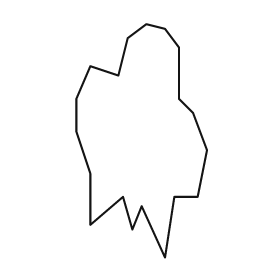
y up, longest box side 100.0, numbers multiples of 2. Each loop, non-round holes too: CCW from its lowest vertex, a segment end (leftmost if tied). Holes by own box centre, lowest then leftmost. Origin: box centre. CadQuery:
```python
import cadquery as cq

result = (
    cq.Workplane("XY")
    .moveTo(10.0, -50.0)
    .lineTo(14.0, -24.0)
    .lineTo(24.0, -24.0)
    .lineTo(28.0, -4.0)
    .lineTo(22.0, 12.0)
    .lineTo(16.0, 18.0)
    .lineTo(16.0, 40.0)
    .lineTo(10.0, 48.0)
    .lineTo(2.0, 50.0)
    .lineTo(-6.0, 44.0)
    .lineTo(-10.0, 28.0)
    .lineTo(-22.0, 32.0)
    .lineTo(-28.0, 18.0)
    .lineTo(-28.0, 4.0)
    .lineTo(-22.0, -14.0)
    .lineTo(-22.0, -36.0)
    .lineTo(-8.0, -24.0)
    .lineTo(-4.0, -38.0)
    .lineTo(0.0, -28.0)
    .close()
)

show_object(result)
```